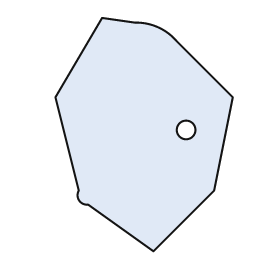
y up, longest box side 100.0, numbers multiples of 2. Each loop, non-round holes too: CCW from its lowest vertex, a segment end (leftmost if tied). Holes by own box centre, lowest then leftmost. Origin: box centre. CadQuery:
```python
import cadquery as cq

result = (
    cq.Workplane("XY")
    .moveTo(4.0, -50.0)
    .lineTo(30.0, -24.0)
    .lineTo(38.0, 16.0)
    .lineTo(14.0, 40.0)
    .threePointArc((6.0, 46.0), (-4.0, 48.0))
    .lineTo(-18.0, 50.0)
    .lineTo(-38.0, 16.0)
    .lineTo(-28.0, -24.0)
    .threePointArc((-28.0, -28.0), (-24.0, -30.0))
    .close()
    .moveTo(18.0, 2.0)
    .circle(4.0)
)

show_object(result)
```